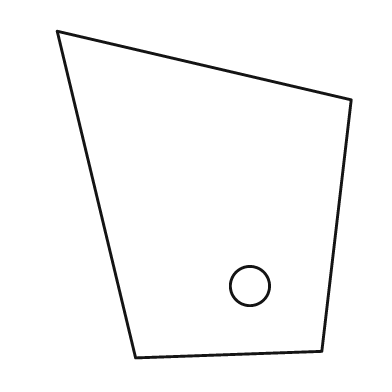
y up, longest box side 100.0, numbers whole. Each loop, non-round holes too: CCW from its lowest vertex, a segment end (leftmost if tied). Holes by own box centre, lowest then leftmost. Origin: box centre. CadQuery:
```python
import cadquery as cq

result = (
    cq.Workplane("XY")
    .moveTo(-21.0, -50.0)
    .lineTo(36.0, -48.0)
    .lineTo(45.0, 29.0)
    .lineTo(-45.0, 50.0)
    .close()
    .moveTo(14.0, -28.0)
    .circle(6.0)
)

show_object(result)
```